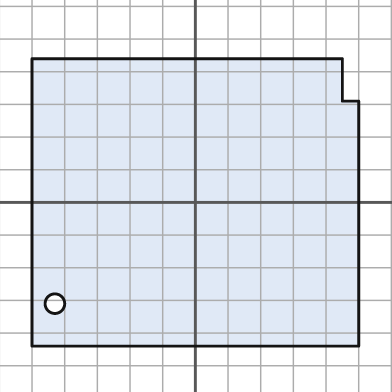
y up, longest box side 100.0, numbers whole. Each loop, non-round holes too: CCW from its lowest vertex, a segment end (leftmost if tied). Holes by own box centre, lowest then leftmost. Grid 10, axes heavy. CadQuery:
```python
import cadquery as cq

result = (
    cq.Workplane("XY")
    .moveTo(-50.0, -44.0)
    .lineTo(50.0, -44.0)
    .lineTo(50.0, 31.0)
    .lineTo(45.0, 31.0)
    .lineTo(45.0, 44.0)
    .lineTo(-50.0, 44.0)
    .close()
    .moveTo(-43.0, -31.0)
    .circle(3.0)
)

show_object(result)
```